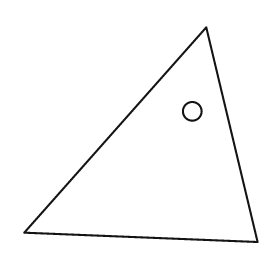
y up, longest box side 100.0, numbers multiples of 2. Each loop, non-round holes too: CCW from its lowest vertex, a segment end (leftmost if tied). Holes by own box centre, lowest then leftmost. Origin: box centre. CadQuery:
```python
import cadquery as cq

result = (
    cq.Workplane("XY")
    .moveTo(50.0, -46.0)
    .lineTo(28.0, 46.0)
    .lineTo(-50.0, -42.0)
    .close()
    .moveTo(22.0, 10.0)
    .circle(4.0)
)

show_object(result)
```